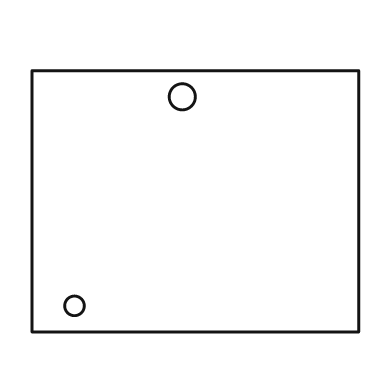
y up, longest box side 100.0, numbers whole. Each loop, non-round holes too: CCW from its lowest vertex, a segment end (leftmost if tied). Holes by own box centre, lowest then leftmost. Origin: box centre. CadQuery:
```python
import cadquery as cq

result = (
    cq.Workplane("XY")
    .moveTo(-50.0, -40.0)
    .lineTo(50.0, -40.0)
    .lineTo(50.0, 40.0)
    .lineTo(-50.0, 40.0)
    .close()
    .moveTo(-37.0, -32.0)
    .circle(3.0)
    .moveTo(-4.0, 32.0)
    .circle(4.0)
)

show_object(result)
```